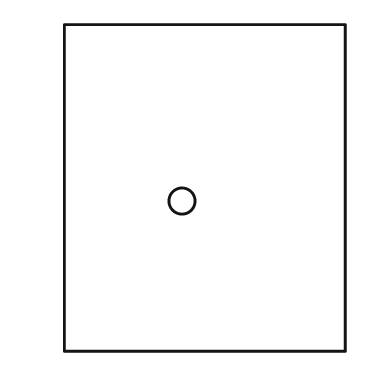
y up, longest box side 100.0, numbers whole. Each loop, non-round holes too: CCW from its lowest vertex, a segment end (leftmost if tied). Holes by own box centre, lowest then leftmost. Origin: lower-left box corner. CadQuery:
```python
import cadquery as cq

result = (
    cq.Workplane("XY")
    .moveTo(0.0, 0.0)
    .lineTo(86.0, 0.0)
    .lineTo(86.0, 100.0)
    .lineTo(0.0, 100.0)
    .close()
    .moveTo(36.0, 46.0)
    .circle(4.0)
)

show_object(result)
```